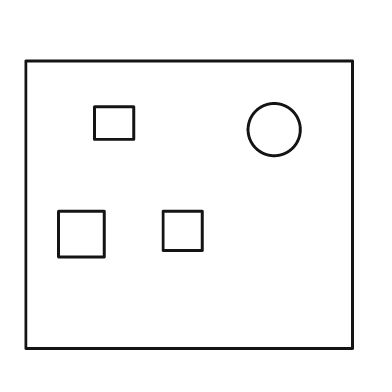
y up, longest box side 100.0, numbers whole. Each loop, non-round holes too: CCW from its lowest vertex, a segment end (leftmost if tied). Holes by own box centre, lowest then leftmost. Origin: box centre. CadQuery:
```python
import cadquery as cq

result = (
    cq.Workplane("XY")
    .moveTo(-50.0, -44.0)
    .lineTo(50.0, -44.0)
    .lineTo(50.0, 44.0)
    .lineTo(-50.0, 44.0)
    .close()
    .moveTo(-40.0, -16.0)
    .lineTo(-26.0, -16.0)
    .lineTo(-26.0, -2.0)
    .lineTo(-40.0, -2.0)
    .close()
    .moveTo(-8.0, -14.0)
    .lineTo(4.0, -14.0)
    .lineTo(4.0, -2.0)
    .lineTo(-8.0, -2.0)
    .close()
    .moveTo(26.0, 23.0)
    .circle(8.0)
    .moveTo(-29.0, 20.0)
    .lineTo(-17.0, 20.0)
    .lineTo(-17.0, 30.0)
    .lineTo(-29.0, 30.0)
    .close()
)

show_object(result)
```